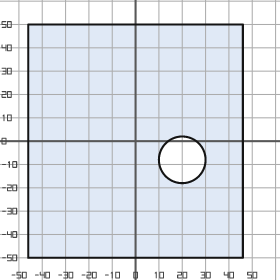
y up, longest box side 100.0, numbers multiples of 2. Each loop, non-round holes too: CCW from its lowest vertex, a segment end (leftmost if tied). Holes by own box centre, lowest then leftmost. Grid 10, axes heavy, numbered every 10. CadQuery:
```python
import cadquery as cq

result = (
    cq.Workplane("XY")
    .moveTo(-46.0, -50.0)
    .lineTo(46.0, -50.0)
    .lineTo(46.0, 50.0)
    .lineTo(-46.0, 50.0)
    .close()
    .moveTo(20.0, -8.0)
    .circle(10.0)
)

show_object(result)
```